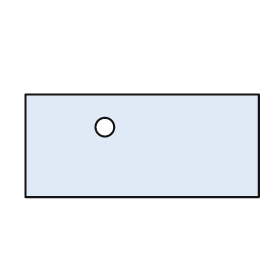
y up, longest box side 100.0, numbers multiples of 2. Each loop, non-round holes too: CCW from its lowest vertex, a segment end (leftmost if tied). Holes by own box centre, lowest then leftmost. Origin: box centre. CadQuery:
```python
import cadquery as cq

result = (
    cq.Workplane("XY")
    .moveTo(-50.0, -22.0)
    .lineTo(50.0, -22.0)
    .lineTo(50.0, 22.0)
    .lineTo(-50.0, 22.0)
    .close()
    .moveTo(-16.0, 8.0)
    .circle(4.0)
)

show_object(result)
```